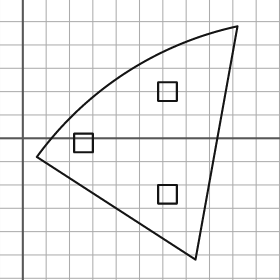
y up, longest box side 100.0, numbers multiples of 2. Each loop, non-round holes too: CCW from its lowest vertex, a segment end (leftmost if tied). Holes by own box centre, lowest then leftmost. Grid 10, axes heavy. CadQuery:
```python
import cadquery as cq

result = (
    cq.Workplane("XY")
    .moveTo(74.0, -52.0)
    .lineTo(92.0, 48.0)
    .threePointArc((44.0, 28.0), (6.0, -8.0))
    .close()
    .moveTo(58.0, -28.0)
    .lineTo(66.0, -28.0)
    .lineTo(66.0, -20.0)
    .lineTo(58.0, -20.0)
    .close()
    .moveTo(22.0, -6.0)
    .lineTo(30.0, -6.0)
    .lineTo(30.0, 2.0)
    .lineTo(22.0, 2.0)
    .close()
    .moveTo(58.0, 16.0)
    .lineTo(66.0, 16.0)
    .lineTo(66.0, 24.0)
    .lineTo(58.0, 24.0)
    .close()
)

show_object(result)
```